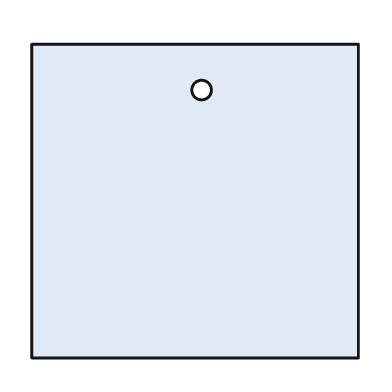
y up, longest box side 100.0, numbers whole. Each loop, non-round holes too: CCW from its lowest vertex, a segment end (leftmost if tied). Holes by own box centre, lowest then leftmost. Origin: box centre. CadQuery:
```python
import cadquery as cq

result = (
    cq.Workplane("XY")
    .moveTo(-50.0, -48.0)
    .lineTo(50.0, -48.0)
    .lineTo(50.0, 48.0)
    .lineTo(-50.0, 48.0)
    .close()
    .moveTo(2.0, 34.0)
    .circle(3.0)
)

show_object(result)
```